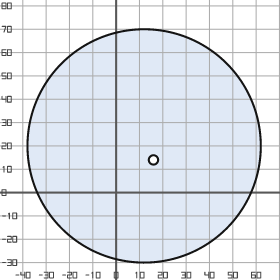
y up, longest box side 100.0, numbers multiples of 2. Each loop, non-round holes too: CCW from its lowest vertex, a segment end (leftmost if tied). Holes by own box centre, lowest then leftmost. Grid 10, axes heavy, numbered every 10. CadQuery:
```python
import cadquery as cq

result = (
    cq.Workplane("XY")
    .moveTo(12.0, 20.0)
    .circle(50.0)
    .moveTo(16.0, 14.0)
    .circle(2.0)
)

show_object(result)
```